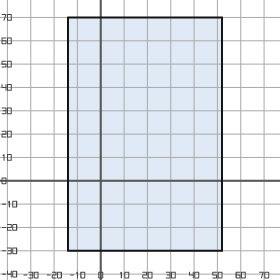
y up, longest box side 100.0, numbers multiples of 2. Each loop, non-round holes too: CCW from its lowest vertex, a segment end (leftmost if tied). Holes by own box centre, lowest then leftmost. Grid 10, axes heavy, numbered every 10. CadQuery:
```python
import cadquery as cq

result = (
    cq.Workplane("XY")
    .moveTo(-14.0, -30.0)
    .lineTo(52.0, -30.0)
    .lineTo(52.0, 70.0)
    .lineTo(-14.0, 70.0)
    .close()
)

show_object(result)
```